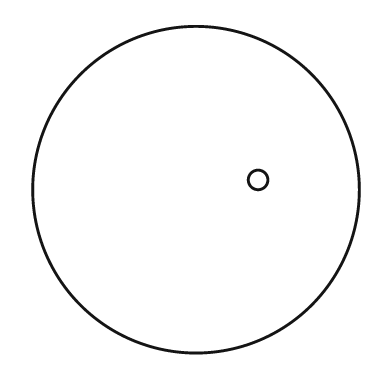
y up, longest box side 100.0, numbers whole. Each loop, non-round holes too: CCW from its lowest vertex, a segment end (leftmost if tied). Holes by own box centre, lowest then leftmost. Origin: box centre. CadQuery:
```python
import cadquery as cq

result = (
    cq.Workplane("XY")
    .moveTo(0.0, 0.0)
    .circle(50.0)
    .moveTo(19.0, 3.0)
    .circle(3.0)
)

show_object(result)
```